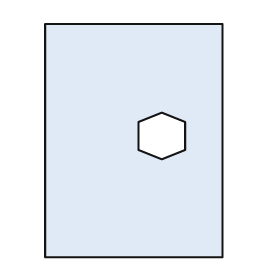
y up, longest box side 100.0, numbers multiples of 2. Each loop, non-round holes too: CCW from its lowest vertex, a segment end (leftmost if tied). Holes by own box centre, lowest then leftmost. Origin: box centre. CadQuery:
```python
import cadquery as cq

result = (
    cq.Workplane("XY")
    .moveTo(-38.0, -50.0)
    .lineTo(38.0, -50.0)
    .lineTo(38.0, 50.0)
    .lineTo(-38.0, 50.0)
    .close()
    .moveTo(12.0, -8.0)
    .lineTo(22.0, -4.0)
    .lineTo(22.0, 8.0)
    .lineTo(12.0, 12.0)
    .lineTo(2.0, 8.0)
    .lineTo(2.0, -4.0)
    .close()
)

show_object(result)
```